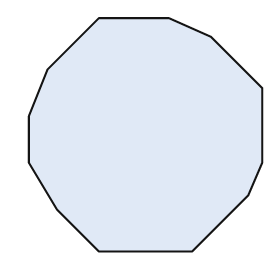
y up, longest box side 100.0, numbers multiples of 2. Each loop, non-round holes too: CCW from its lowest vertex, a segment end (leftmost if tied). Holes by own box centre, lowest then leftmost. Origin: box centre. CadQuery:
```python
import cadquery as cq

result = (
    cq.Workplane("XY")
    .moveTo(-20.0, -50.0)
    .lineTo(20.0, -50.0)
    .lineTo(44.0, -26.0)
    .lineTo(50.0, -12.0)
    .lineTo(50.0, 20.0)
    .lineTo(28.0, 42.0)
    .lineTo(10.0, 50.0)
    .lineTo(-20.0, 50.0)
    .lineTo(-42.0, 28.0)
    .lineTo(-50.0, 8.0)
    .lineTo(-50.0, -12.0)
    .lineTo(-38.0, -32.0)
    .close()
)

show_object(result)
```